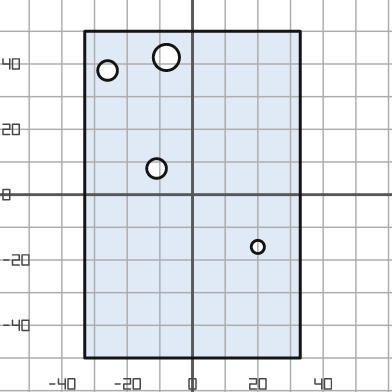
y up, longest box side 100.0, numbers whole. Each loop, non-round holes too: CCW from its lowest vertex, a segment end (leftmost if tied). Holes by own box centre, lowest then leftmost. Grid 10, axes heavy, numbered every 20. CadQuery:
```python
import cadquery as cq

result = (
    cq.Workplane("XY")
    .moveTo(-33.0, -50.0)
    .lineTo(33.0, -50.0)
    .lineTo(33.0, 50.0)
    .lineTo(-33.0, 50.0)
    .close()
    .moveTo(20.0, -16.0)
    .circle(2.0)
    .moveTo(-11.0, 8.0)
    .circle(3.0)
    .moveTo(-26.0, 38.0)
    .circle(3.0)
    .moveTo(-8.0, 42.0)
    .circle(4.0)
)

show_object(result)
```